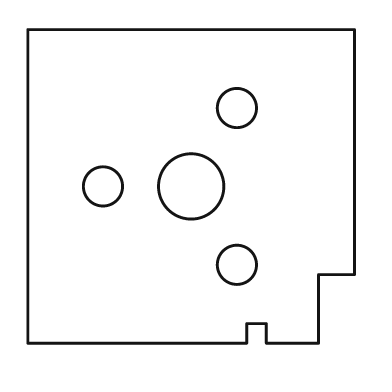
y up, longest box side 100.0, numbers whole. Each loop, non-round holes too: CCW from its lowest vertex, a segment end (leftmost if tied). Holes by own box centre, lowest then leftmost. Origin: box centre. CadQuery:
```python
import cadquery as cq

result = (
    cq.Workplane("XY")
    .moveTo(-50.0, -48.0)
    .lineTo(17.0, -48.0)
    .lineTo(17.0, -42.0)
    .lineTo(23.0, -42.0)
    .lineTo(23.0, -48.0)
    .lineTo(39.0, -48.0)
    .lineTo(39.0, -27.0)
    .lineTo(50.0, -27.0)
    .lineTo(50.0, 48.0)
    .lineTo(-50.0, 48.0)
    .close()
    .moveTo(14.0, -24.0)
    .circle(6.0)
    .moveTo(-27.0, 0.0)
    .circle(6.0)
    .moveTo(0.0, 0.0)
    .circle(10.0)
    .moveTo(14.0, 24.0)
    .circle(6.0)
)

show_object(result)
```